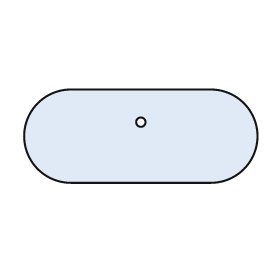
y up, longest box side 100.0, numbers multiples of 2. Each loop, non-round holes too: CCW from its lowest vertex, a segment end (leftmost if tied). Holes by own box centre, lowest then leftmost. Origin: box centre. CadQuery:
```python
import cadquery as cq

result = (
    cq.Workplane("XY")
    .moveTo(-30.0, -20.0)
    .lineTo(30.0, -20.0)
    .threePointArc((50.0, 0.0), (30.0, 20.0))
    .lineTo(-30.0, 20.0)
    .threePointArc((-50.0, 0.0), (-30.0, -20.0))
    .close()
    .moveTo(0.0, 6.0)
    .circle(2.0)
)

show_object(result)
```